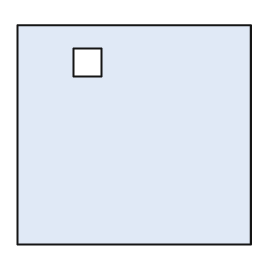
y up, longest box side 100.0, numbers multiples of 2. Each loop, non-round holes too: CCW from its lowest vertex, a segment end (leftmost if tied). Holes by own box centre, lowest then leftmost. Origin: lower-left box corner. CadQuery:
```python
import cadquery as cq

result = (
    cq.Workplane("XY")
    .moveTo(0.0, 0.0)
    .lineTo(100.0, 0.0)
    .lineTo(100.0, 94.0)
    .lineTo(0.0, 94.0)
    .close()
    .moveTo(24.0, 72.0)
    .lineTo(36.0, 72.0)
    .lineTo(36.0, 84.0)
    .lineTo(24.0, 84.0)
    .close()
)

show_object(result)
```